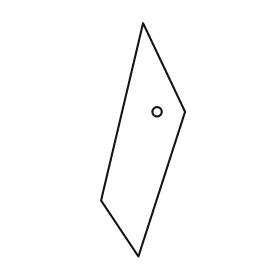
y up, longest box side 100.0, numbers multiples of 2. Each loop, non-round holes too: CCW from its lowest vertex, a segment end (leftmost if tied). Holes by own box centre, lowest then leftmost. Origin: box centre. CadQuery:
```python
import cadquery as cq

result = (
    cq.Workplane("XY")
    .moveTo(-2.0, -50.0)
    .lineTo(18.0, 12.0)
    .lineTo(0.0, 50.0)
    .lineTo(-18.0, -26.0)
    .close()
    .moveTo(6.0, 12.0)
    .circle(2.0)
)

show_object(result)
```